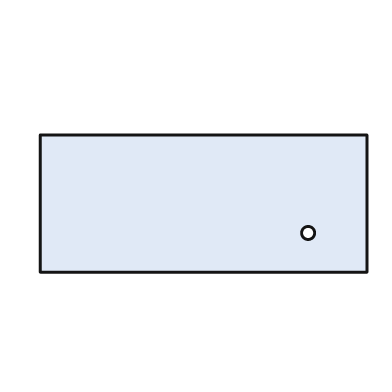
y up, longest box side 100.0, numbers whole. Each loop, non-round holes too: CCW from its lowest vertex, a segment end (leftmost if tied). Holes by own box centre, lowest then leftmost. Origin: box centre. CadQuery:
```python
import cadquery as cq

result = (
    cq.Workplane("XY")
    .moveTo(-50.0, -21.0)
    .lineTo(50.0, -21.0)
    .lineTo(50.0, 21.0)
    .lineTo(-50.0, 21.0)
    .close()
    .moveTo(32.0, -9.0)
    .circle(2.0)
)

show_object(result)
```